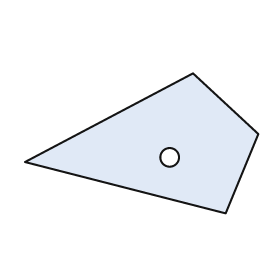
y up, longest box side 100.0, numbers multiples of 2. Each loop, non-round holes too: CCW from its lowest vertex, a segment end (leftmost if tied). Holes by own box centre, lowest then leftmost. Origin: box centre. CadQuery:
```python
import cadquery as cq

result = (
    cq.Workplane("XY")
    .moveTo(36.0, -30.0)
    .lineTo(50.0, 4.0)
    .lineTo(22.0, 30.0)
    .lineTo(-50.0, -8.0)
    .close()
    .moveTo(12.0, -6.0)
    .circle(4.0)
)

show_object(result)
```